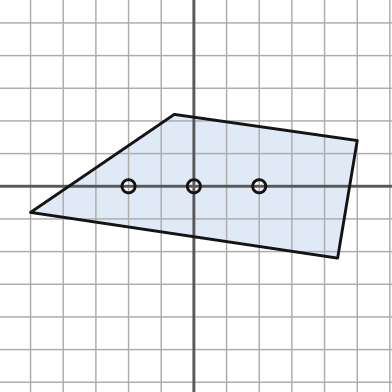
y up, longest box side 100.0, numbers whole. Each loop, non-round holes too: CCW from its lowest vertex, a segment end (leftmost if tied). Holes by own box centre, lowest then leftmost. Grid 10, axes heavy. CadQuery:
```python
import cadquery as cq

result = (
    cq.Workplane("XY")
    .moveTo(44.0, -22.0)
    .lineTo(50.0, 14.0)
    .lineTo(-6.0, 22.0)
    .lineTo(-50.0, -8.0)
    .close()
    .moveTo(-20.0, 0.0)
    .circle(2.0)
    .moveTo(0.0, 0.0)
    .circle(2.0)
    .moveTo(20.0, 0.0)
    .circle(2.0)
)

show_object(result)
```